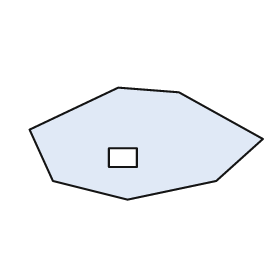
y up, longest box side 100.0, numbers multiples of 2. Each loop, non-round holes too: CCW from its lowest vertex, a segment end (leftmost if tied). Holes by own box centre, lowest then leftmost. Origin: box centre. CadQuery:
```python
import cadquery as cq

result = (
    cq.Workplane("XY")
    .moveTo(-8.0, -24.0)
    .lineTo(30.0, -16.0)
    .lineTo(50.0, 2.0)
    .lineTo(14.0, 22.0)
    .lineTo(-12.0, 24.0)
    .lineTo(-50.0, 6.0)
    .lineTo(-40.0, -16.0)
    .close()
    .moveTo(-16.0, -10.0)
    .lineTo(-4.0, -10.0)
    .lineTo(-4.0, -2.0)
    .lineTo(-16.0, -2.0)
    .close()
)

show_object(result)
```